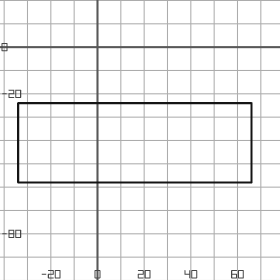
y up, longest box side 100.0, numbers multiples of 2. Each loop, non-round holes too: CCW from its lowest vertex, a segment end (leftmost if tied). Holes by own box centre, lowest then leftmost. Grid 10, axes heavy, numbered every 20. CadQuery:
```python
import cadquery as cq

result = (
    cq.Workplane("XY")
    .moveTo(-34.0, -58.0)
    .lineTo(66.0, -58.0)
    .lineTo(66.0, -24.0)
    .lineTo(-34.0, -24.0)
    .close()
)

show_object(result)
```